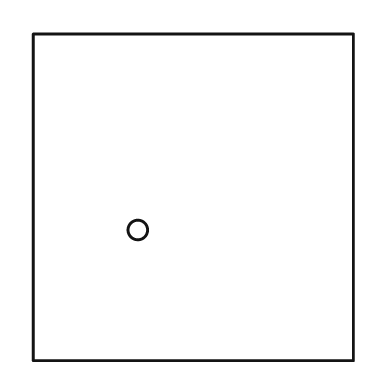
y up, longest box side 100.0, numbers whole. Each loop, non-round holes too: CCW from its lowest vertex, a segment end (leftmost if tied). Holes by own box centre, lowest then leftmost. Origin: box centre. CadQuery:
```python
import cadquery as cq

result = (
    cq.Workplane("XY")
    .moveTo(-49.0, -50.0)
    .lineTo(49.0, -50.0)
    .lineTo(49.0, 50.0)
    .lineTo(-49.0, 50.0)
    .close()
    .moveTo(-17.0, -10.0)
    .circle(3.0)
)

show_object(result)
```